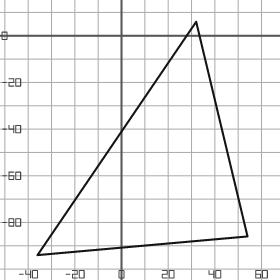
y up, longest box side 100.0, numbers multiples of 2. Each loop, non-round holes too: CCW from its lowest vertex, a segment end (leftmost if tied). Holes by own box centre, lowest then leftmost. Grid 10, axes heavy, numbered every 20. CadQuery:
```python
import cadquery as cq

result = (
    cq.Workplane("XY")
    .moveTo(-36.0, -94.0)
    .lineTo(54.0, -86.0)
    .lineTo(32.0, 6.0)
    .close()
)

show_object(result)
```